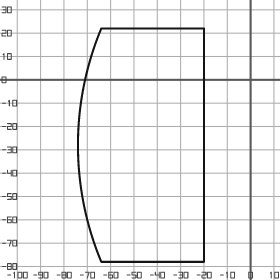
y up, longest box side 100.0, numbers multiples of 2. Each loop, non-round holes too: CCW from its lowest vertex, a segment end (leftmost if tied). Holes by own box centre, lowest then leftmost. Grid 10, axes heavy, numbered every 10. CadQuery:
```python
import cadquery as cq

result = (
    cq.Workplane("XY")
    .moveTo(-64.0, -78.0)
    .lineTo(-20.0, -78.0)
    .lineTo(-20.0, 22.0)
    .lineTo(-64.0, 22.0)
    .threePointArc((-74.0, -28.0), (-64.0, -78.0))
    .close()
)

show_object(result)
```